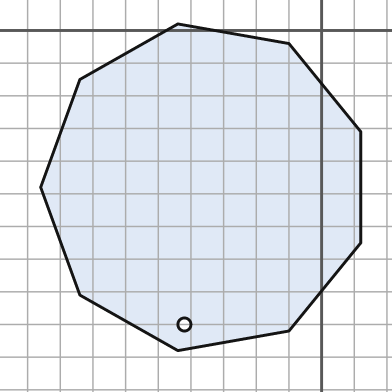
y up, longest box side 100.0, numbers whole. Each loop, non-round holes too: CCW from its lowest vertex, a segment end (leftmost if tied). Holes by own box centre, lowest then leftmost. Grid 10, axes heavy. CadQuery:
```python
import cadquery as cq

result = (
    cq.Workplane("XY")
    .moveTo(-44.0, -98.0)
    .lineTo(-10.0, -92.0)
    .lineTo(12.0, -65.0)
    .lineTo(12.0, -31.0)
    .lineTo(-10.0, -4.0)
    .lineTo(-44.0, 2.0)
    .lineTo(-74.0, -15.0)
    .lineTo(-86.0, -48.0)
    .lineTo(-74.0, -81.0)
    .close()
    .moveTo(-42.0, -90.0)
    .circle(2.0)
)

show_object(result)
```